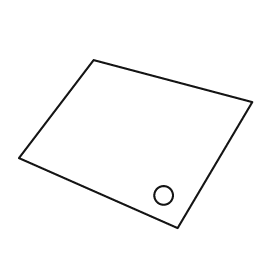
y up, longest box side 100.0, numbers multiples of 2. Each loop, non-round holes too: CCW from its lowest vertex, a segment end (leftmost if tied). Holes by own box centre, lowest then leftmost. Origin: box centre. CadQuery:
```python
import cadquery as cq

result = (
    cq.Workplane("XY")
    .moveTo(18.0, -36.0)
    .lineTo(50.0, 18.0)
    .lineTo(-18.0, 36.0)
    .lineTo(-50.0, -6.0)
    .close()
    .moveTo(12.0, -22.0)
    .circle(4.0)
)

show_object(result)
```